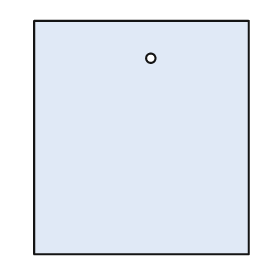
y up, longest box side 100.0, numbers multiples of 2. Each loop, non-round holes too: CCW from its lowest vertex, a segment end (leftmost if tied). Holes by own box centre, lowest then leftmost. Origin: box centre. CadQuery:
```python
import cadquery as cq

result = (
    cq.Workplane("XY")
    .moveTo(-46.0, -50.0)
    .lineTo(46.0, -50.0)
    .lineTo(46.0, 50.0)
    .lineTo(-46.0, 50.0)
    .close()
    .moveTo(4.0, 34.0)
    .circle(2.0)
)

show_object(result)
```